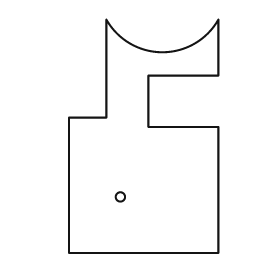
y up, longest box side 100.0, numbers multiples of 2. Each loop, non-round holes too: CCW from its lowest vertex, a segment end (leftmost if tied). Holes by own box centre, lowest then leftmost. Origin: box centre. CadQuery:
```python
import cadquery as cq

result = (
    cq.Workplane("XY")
    .moveTo(-32.0, -50.0)
    .lineTo(32.0, -50.0)
    .lineTo(32.0, 4.0)
    .lineTo(2.0, 4.0)
    .lineTo(2.0, 26.0)
    .lineTo(32.0, 26.0)
    .lineTo(32.0, 50.0)
    .threePointArc((8.0, 36.0), (-16.0, 50.0))
    .lineTo(-16.0, 8.0)
    .lineTo(-32.0, 8.0)
    .close()
    .moveTo(-10.0, -26.0)
    .circle(2.0)
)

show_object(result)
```